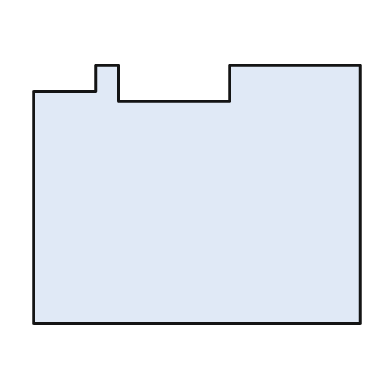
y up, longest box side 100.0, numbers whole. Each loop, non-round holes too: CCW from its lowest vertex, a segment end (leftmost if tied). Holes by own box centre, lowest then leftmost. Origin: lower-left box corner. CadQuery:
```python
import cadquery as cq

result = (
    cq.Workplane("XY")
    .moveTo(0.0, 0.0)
    .lineTo(100.0, 0.0)
    .lineTo(100.0, 79.0)
    .lineTo(60.0, 79.0)
    .lineTo(60.0, 68.0)
    .lineTo(26.0, 68.0)
    .lineTo(26.0, 79.0)
    .lineTo(19.0, 79.0)
    .lineTo(19.0, 71.0)
    .lineTo(0.0, 71.0)
    .close()
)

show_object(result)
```